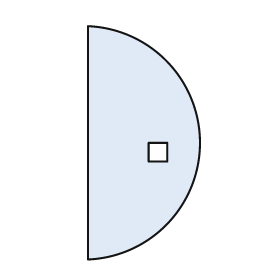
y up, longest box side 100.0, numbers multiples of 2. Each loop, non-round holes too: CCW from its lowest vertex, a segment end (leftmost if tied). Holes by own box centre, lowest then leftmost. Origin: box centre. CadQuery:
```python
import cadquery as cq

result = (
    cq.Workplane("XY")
    .moveTo(-24.0, -50.0)
    .threePointArc((24.0, 0.0), (-24.0, 50.0))
    .close()
    .moveTo(2.0, -8.0)
    .lineTo(10.0, -8.0)
    .lineTo(10.0, 0.0)
    .lineTo(2.0, 0.0)
    .close()
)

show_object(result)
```